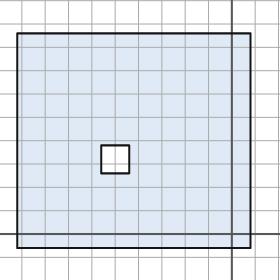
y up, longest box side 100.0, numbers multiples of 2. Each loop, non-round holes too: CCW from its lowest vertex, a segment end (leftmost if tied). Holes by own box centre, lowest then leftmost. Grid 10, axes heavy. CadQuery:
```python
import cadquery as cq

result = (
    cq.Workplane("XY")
    .moveTo(-92.0, -6.0)
    .lineTo(8.0, -6.0)
    .lineTo(8.0, 86.0)
    .lineTo(-92.0, 86.0)
    .close()
    .moveTo(-56.0, 26.0)
    .lineTo(-44.0, 26.0)
    .lineTo(-44.0, 38.0)
    .lineTo(-56.0, 38.0)
    .close()
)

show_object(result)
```